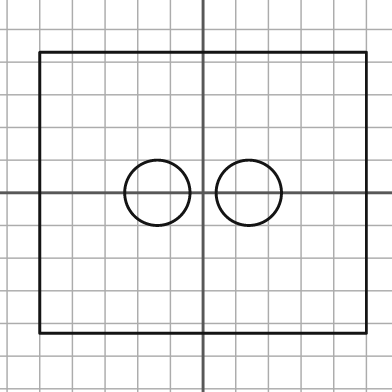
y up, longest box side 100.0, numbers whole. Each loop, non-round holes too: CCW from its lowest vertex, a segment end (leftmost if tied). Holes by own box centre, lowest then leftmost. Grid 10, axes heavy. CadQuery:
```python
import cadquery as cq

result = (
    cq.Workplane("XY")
    .moveTo(-50.0, -43.0)
    .lineTo(50.0, -43.0)
    .lineTo(50.0, 43.0)
    .lineTo(-50.0, 43.0)
    .close()
    .moveTo(-14.0, 0.0)
    .circle(10.0)
    .moveTo(14.0, 0.0)
    .circle(10.0)
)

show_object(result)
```